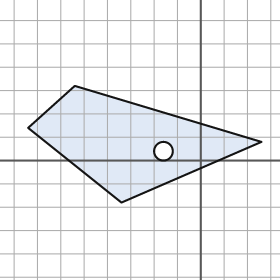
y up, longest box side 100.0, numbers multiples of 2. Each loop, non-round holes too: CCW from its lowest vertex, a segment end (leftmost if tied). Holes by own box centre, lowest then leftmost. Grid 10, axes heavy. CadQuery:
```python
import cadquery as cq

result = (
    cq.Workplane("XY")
    .moveTo(-34.0, -18.0)
    .lineTo(26.0, 8.0)
    .lineTo(-54.0, 32.0)
    .lineTo(-74.0, 14.0)
    .close()
    .moveTo(-16.0, 4.0)
    .circle(4.0)
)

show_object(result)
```